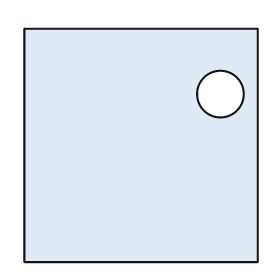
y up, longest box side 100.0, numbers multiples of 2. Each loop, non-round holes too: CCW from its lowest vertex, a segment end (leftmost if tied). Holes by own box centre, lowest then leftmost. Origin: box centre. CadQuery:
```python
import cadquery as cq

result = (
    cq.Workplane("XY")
    .moveTo(-50.0, -50.0)
    .lineTo(50.0, -50.0)
    .lineTo(50.0, 50.0)
    .lineTo(-50.0, 50.0)
    .close()
    .moveTo(34.0, 22.0)
    .circle(10.0)
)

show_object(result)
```